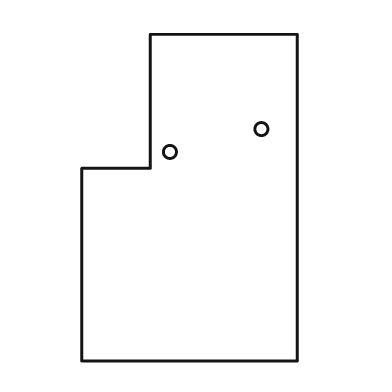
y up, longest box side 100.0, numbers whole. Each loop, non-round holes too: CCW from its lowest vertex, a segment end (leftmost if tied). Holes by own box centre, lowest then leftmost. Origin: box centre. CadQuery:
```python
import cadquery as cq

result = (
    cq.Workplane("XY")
    .moveTo(-33.0, -50.0)
    .lineTo(33.0, -50.0)
    .lineTo(33.0, 50.0)
    .lineTo(-12.0, 50.0)
    .lineTo(-12.0, 9.0)
    .lineTo(-33.0, 9.0)
    .close()
    .moveTo(-6.0, 14.0)
    .circle(2.0)
    .moveTo(22.0, 21.0)
    .circle(2.0)
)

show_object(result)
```